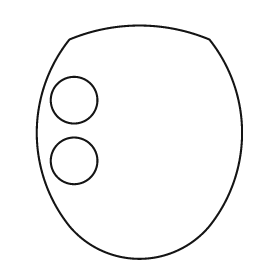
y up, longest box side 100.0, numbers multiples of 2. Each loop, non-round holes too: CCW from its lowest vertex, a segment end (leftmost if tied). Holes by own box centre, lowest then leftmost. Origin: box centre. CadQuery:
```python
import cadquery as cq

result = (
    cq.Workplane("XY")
    .moveTo(-30.0, -36.0)
    .threePointArc((0.0, -50.0), (30.0, -36.0))
    .threePointArc((44.0, 4.0), (30.0, 44.0))
    .threePointArc((0.0, 50.0), (-30.0, 44.0))
    .threePointArc((-44.0, 4.0), (-30.0, -36.0))
    .close()
    .moveTo(-28.0, -8.0)
    .circle(10.0)
    .moveTo(-28.0, 18.0)
    .circle(10.0)
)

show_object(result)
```